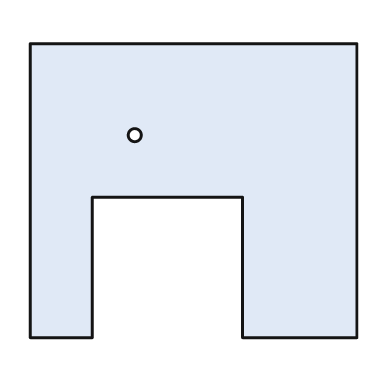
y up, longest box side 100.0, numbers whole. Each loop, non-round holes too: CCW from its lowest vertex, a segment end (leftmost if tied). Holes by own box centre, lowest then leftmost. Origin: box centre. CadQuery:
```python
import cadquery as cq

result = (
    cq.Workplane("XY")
    .moveTo(-50.0, -45.0)
    .lineTo(-31.0, -45.0)
    .lineTo(-31.0, -2.0)
    .lineTo(15.0, -2.0)
    .lineTo(15.0, -45.0)
    .lineTo(50.0, -45.0)
    .lineTo(50.0, 45.0)
    .lineTo(-50.0, 45.0)
    .close()
    .moveTo(-18.0, 17.0)
    .circle(2.0)
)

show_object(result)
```